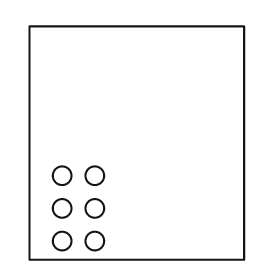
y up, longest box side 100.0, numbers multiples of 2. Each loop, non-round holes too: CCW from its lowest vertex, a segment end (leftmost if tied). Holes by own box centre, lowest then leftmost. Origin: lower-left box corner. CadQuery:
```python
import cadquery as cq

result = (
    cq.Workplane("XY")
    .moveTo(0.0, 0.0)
    .lineTo(92.0, 0.0)
    .lineTo(92.0, 100.0)
    .lineTo(0.0, 100.0)
    .close()
    .moveTo(14.0, 8.0)
    .circle(4.0)
    .moveTo(28.0, 8.0)
    .circle(4.0)
    .moveTo(14.0, 22.0)
    .circle(4.0)
    .moveTo(28.0, 22.0)
    .circle(4.0)
    .moveTo(14.0, 36.0)
    .circle(4.0)
    .moveTo(28.0, 36.0)
    .circle(4.0)
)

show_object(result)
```